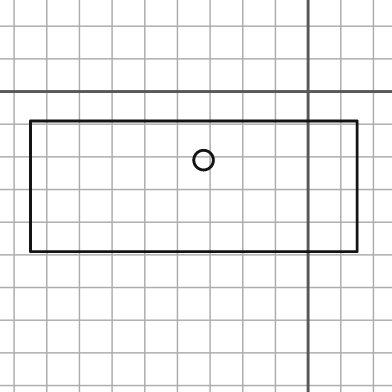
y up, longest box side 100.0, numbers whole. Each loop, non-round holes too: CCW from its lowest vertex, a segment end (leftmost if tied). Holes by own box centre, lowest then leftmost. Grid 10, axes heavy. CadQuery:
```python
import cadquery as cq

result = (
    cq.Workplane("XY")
    .moveTo(-85.0, -49.0)
    .lineTo(15.0, -49.0)
    .lineTo(15.0, -9.0)
    .lineTo(-85.0, -9.0)
    .close()
    .moveTo(-32.0, -21.0)
    .circle(3.0)
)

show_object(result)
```